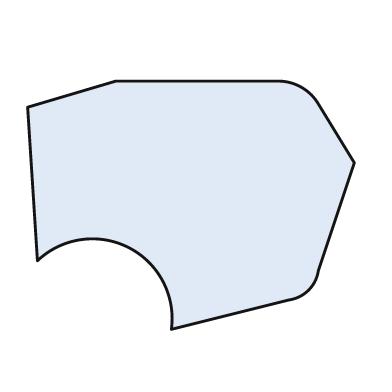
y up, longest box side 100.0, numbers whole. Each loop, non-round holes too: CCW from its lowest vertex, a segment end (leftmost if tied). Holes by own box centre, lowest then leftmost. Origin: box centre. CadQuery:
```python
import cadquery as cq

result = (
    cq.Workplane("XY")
    .moveTo(-6.0, -38.0)
    .lineTo(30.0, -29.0)
    .threePointArc((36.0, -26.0), (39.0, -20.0))
    .lineTo(50.0, 13.0)
    .lineTo(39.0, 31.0)
    .threePointArc((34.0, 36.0), (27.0, 38.0))
    .lineTo(-23.0, 38.0)
    .lineTo(-50.0, 30.0)
    .lineTo(-47.0, -17.0)
    .threePointArc((-19.0, -13.0), (-6.0, -38.0))
    .close()
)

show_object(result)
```